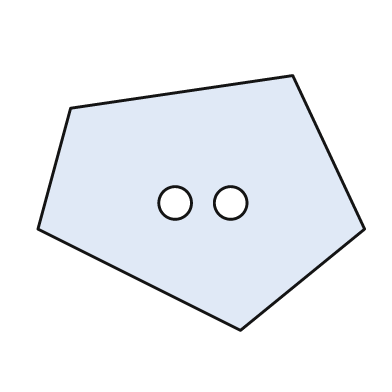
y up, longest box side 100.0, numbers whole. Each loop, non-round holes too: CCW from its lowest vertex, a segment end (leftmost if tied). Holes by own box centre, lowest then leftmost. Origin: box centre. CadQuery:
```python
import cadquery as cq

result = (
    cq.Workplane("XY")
    .moveTo(12.0, -39.0)
    .lineTo(50.0, -8.0)
    .lineTo(28.0, 39.0)
    .lineTo(-40.0, 29.0)
    .lineTo(-50.0, -8.0)
    .close()
    .moveTo(-8.0, 0.0)
    .circle(5.0)
    .moveTo(9.0, 0.0)
    .circle(5.0)
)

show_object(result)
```